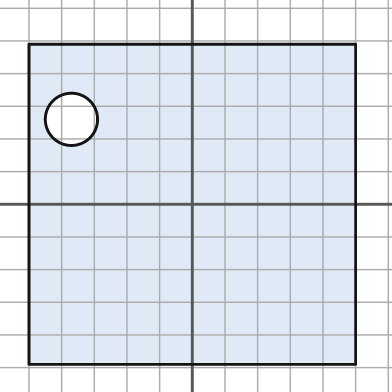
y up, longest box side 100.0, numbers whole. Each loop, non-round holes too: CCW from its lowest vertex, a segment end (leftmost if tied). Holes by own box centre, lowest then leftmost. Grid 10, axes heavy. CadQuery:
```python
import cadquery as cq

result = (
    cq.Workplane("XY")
    .moveTo(-50.0, -49.0)
    .lineTo(50.0, -49.0)
    .lineTo(50.0, 49.0)
    .lineTo(-50.0, 49.0)
    .close()
    .moveTo(-37.0, 26.0)
    .circle(8.0)
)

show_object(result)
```